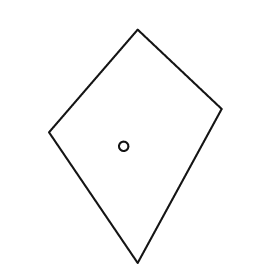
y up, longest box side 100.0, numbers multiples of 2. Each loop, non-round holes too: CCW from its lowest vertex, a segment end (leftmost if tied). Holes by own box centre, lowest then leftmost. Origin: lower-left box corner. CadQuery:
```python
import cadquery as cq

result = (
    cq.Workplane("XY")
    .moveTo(38.0, 0.0)
    .lineTo(74.0, 66.0)
    .lineTo(38.0, 100.0)
    .lineTo(0.0, 56.0)
    .close()
    .moveTo(32.0, 50.0)
    .circle(2.0)
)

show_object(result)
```